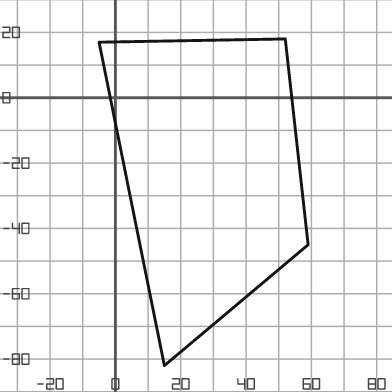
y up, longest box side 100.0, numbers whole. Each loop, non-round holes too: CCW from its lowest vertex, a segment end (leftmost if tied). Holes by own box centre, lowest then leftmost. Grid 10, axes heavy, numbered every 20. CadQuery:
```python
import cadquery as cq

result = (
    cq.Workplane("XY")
    .moveTo(15.0, -82.0)
    .lineTo(59.0, -45.0)
    .lineTo(52.0, 18.0)
    .lineTo(-5.0, 17.0)
    .close()
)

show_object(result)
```